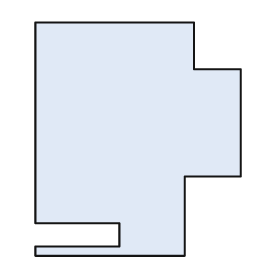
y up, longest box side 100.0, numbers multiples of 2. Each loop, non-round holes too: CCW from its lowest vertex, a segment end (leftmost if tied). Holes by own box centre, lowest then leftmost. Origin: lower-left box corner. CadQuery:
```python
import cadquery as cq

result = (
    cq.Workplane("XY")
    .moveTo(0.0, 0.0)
    .lineTo(64.0, 0.0)
    .lineTo(64.0, 34.0)
    .lineTo(88.0, 34.0)
    .lineTo(88.0, 80.0)
    .lineTo(68.0, 80.0)
    .lineTo(68.0, 100.0)
    .lineTo(0.0, 100.0)
    .lineTo(0.0, 14.0)
    .lineTo(36.0, 14.0)
    .lineTo(36.0, 4.0)
    .lineTo(0.0, 4.0)
    .close()
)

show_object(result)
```